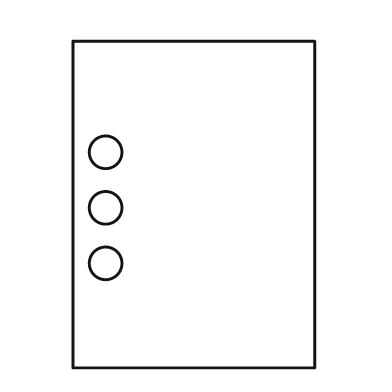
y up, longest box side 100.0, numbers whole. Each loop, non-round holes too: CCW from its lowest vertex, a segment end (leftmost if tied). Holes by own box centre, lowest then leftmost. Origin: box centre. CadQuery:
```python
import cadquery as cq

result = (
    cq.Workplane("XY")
    .moveTo(-37.0, -50.0)
    .lineTo(37.0, -50.0)
    .lineTo(37.0, 50.0)
    .lineTo(-37.0, 50.0)
    .close()
    .moveTo(-27.0, -18.0)
    .circle(5.0)
    .moveTo(-27.0, -1.0)
    .circle(5.0)
    .moveTo(-27.0, 16.0)
    .circle(5.0)
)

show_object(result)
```